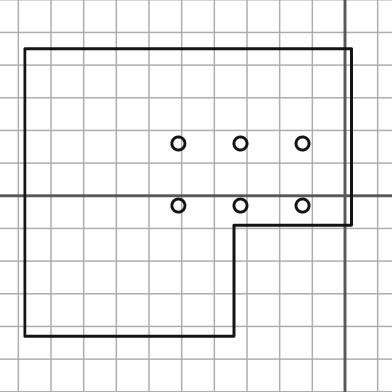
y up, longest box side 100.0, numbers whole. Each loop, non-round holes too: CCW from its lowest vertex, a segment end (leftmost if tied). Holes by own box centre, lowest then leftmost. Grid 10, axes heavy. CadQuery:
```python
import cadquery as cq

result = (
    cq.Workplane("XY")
    .moveTo(-98.0, -43.0)
    .lineTo(-34.0, -43.0)
    .lineTo(-34.0, -9.0)
    .lineTo(2.0, -9.0)
    .lineTo(2.0, 45.0)
    .lineTo(-98.0, 45.0)
    .close()
    .moveTo(-51.0, -3.0)
    .circle(2.0)
    .moveTo(-32.0, -3.0)
    .circle(2.0)
    .moveTo(-13.0, -3.0)
    .circle(2.0)
    .moveTo(-51.0, 16.0)
    .circle(2.0)
    .moveTo(-32.0, 16.0)
    .circle(2.0)
    .moveTo(-13.0, 16.0)
    .circle(2.0)
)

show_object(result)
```